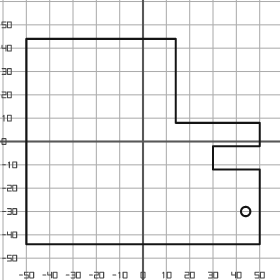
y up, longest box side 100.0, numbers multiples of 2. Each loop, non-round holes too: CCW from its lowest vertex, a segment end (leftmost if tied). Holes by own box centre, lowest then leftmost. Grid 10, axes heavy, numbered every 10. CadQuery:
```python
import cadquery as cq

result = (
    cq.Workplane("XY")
    .moveTo(-50.0, -44.0)
    .lineTo(50.0, -44.0)
    .lineTo(50.0, -12.0)
    .lineTo(30.0, -12.0)
    .lineTo(30.0, -2.0)
    .lineTo(50.0, -2.0)
    .lineTo(50.0, 8.0)
    .lineTo(14.0, 8.0)
    .lineTo(14.0, 44.0)
    .lineTo(-50.0, 44.0)
    .close()
    .moveTo(44.0, -30.0)
    .circle(2.0)
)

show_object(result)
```